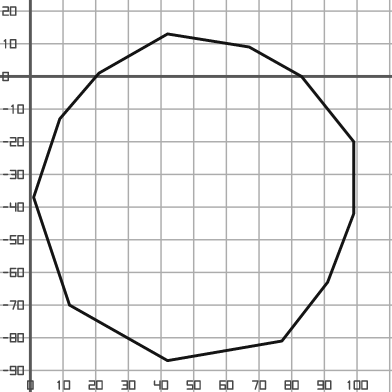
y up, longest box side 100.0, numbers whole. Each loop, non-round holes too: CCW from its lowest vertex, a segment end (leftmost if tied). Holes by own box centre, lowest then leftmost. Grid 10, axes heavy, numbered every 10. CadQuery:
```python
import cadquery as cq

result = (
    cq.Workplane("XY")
    .moveTo(42.0, -87.0)
    .lineTo(77.0, -81.0)
    .lineTo(91.0, -63.0)
    .lineTo(99.0, -42.0)
    .lineTo(99.0, -20.0)
    .lineTo(83.0, 0.0)
    .lineTo(67.0, 9.0)
    .lineTo(42.0, 13.0)
    .lineTo(21.0, 1.0)
    .lineTo(9.0, -13.0)
    .lineTo(1.0, -37.0)
    .lineTo(12.0, -70.0)
    .close()
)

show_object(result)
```